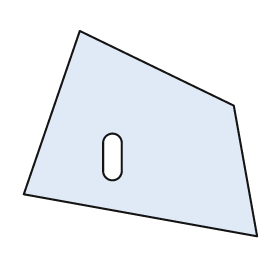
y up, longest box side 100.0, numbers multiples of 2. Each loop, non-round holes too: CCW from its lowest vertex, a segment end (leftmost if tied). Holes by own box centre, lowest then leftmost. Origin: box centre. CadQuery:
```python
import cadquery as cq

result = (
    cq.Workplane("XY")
    .moveTo(50.0, -44.0)
    .lineTo(40.0, 12.0)
    .lineTo(-26.0, 44.0)
    .lineTo(-50.0, -26.0)
    .close()
    .moveTo(-16.0, -16.0)
    .threePointArc((-12.0, -20.0), (-8.0, -16.0))
    .lineTo(-8.0, -4.0)
    .threePointArc((-12.0, 0.0), (-16.0, -4.0))
    .close()
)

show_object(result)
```